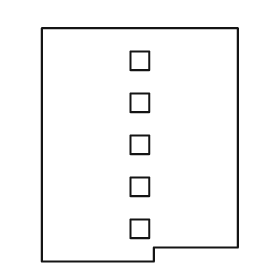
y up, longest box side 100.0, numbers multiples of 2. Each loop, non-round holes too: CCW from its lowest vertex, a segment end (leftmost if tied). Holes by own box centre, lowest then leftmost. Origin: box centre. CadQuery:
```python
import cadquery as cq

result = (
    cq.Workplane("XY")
    .moveTo(-42.0, -50.0)
    .lineTo(6.0, -50.0)
    .lineTo(6.0, -44.0)
    .lineTo(42.0, -44.0)
    .lineTo(42.0, 50.0)
    .lineTo(-42.0, 50.0)
    .close()
    .moveTo(-4.0, -40.0)
    .lineTo(4.0, -40.0)
    .lineTo(4.0, -32.0)
    .lineTo(-4.0, -32.0)
    .close()
    .moveTo(-4.0, -22.0)
    .lineTo(4.0, -22.0)
    .lineTo(4.0, -14.0)
    .lineTo(-4.0, -14.0)
    .close()
    .moveTo(-4.0, -4.0)
    .lineTo(4.0, -4.0)
    .lineTo(4.0, 4.0)
    .lineTo(-4.0, 4.0)
    .close()
    .moveTo(-4.0, 14.0)
    .lineTo(4.0, 14.0)
    .lineTo(4.0, 22.0)
    .lineTo(-4.0, 22.0)
    .close()
    .moveTo(-4.0, 32.0)
    .lineTo(4.0, 32.0)
    .lineTo(4.0, 40.0)
    .lineTo(-4.0, 40.0)
    .close()
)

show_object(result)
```